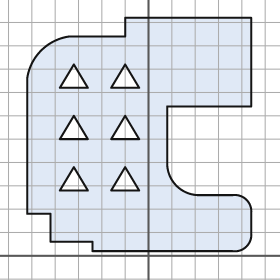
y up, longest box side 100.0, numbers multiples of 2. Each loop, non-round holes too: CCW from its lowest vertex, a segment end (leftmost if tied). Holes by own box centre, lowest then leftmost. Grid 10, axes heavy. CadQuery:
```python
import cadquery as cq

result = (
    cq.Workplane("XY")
    .moveTo(-24.0, 2.0)
    .lineTo(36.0, 2.0)
    .threePointArc((42.0, 4.0), (44.0, 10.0))
    .lineTo(44.0, 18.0)
    .threePointArc((42.0, 24.0), (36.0, 26.0))
    .lineTo(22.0, 26.0)
    .threePointArc((12.0, 30.0), (8.0, 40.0))
    .lineTo(8.0, 64.0)
    .lineTo(44.0, 64.0)
    .lineTo(44.0, 102.0)
    .lineTo(-10.0, 102.0)
    .lineTo(-10.0, 94.0)
    .lineTo(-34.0, 94.0)
    .threePointArc((-46.0, 88.0), (-52.0, 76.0))
    .lineTo(-52.0, 18.0)
    .lineTo(-42.0, 18.0)
    .lineTo(-42.0, 6.0)
    .lineTo(-24.0, 6.0)
    .close()
    .moveTo(-38.0, 28.0)
    .lineTo(-26.0, 28.0)
    .lineTo(-32.0, 38.0)
    .close()
    .moveTo(-16.0, 28.0)
    .lineTo(-4.0, 28.0)
    .lineTo(-10.0, 38.0)
    .close()
    .moveTo(-38.0, 50.0)
    .lineTo(-26.0, 50.0)
    .lineTo(-32.0, 60.0)
    .close()
    .moveTo(-16.0, 50.0)
    .lineTo(-4.0, 50.0)
    .lineTo(-10.0, 60.0)
    .close()
    .moveTo(-38.0, 72.0)
    .lineTo(-26.0, 72.0)
    .lineTo(-32.0, 82.0)
    .close()
    .moveTo(-16.0, 72.0)
    .lineTo(-4.0, 72.0)
    .lineTo(-10.0, 82.0)
    .close()
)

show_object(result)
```